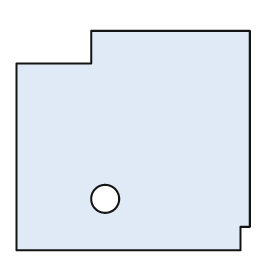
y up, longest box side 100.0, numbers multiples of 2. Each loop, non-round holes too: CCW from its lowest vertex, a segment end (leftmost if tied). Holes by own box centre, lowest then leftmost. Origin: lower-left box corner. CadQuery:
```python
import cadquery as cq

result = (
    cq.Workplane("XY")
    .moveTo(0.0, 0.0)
    .lineTo(96.0, 0.0)
    .lineTo(96.0, 10.0)
    .lineTo(100.0, 10.0)
    .lineTo(100.0, 94.0)
    .lineTo(32.0, 94.0)
    .lineTo(32.0, 80.0)
    .lineTo(0.0, 80.0)
    .close()
    .moveTo(38.0, 22.0)
    .circle(6.0)
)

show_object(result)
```